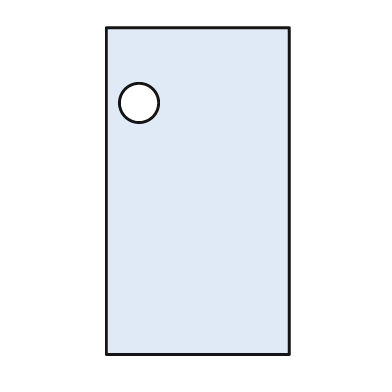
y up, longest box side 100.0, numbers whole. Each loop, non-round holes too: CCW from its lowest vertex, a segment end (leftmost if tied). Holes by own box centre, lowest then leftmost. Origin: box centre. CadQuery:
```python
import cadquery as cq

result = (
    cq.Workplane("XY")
    .moveTo(-28.0, -50.0)
    .lineTo(28.0, -50.0)
    .lineTo(28.0, 50.0)
    .lineTo(-28.0, 50.0)
    .close()
    .moveTo(-18.0, 27.0)
    .circle(6.0)
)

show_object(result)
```